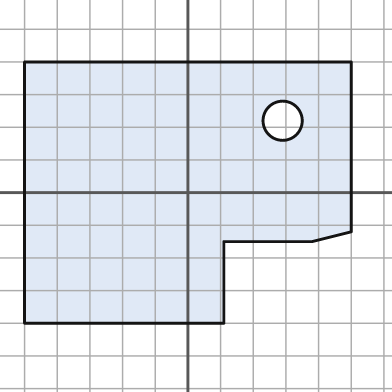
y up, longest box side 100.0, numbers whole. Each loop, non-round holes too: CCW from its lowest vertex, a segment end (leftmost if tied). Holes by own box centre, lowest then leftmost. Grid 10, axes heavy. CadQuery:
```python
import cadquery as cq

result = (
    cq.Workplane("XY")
    .moveTo(-50.0, -40.0)
    .lineTo(11.0, -40.0)
    .lineTo(11.0, -15.0)
    .lineTo(38.0, -15.0)
    .lineTo(50.0, -12.0)
    .lineTo(50.0, 40.0)
    .lineTo(-50.0, 40.0)
    .close()
    .moveTo(29.0, 22.0)
    .circle(6.0)
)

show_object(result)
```